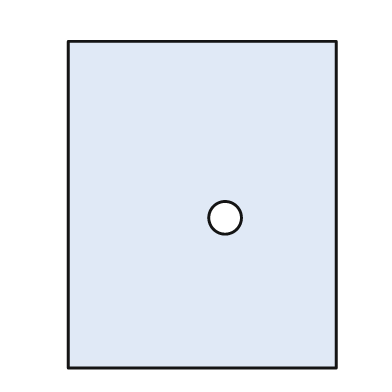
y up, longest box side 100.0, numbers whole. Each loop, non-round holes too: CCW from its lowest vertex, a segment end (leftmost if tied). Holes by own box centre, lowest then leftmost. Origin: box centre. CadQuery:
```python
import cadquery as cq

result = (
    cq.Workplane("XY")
    .moveTo(-41.0, -50.0)
    .lineTo(41.0, -50.0)
    .lineTo(41.0, 50.0)
    .lineTo(-41.0, 50.0)
    .close()
    .moveTo(7.0, -4.0)
    .circle(5.0)
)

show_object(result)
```